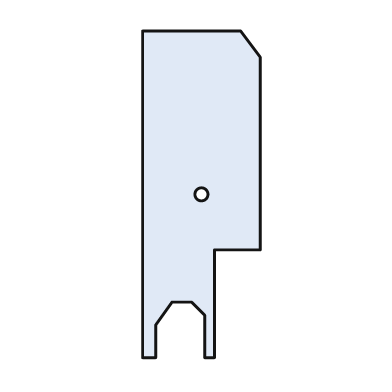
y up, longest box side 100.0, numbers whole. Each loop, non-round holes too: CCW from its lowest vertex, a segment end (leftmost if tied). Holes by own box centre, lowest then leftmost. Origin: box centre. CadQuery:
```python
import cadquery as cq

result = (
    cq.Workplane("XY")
    .moveTo(-18.0, -50.0)
    .lineTo(-14.0, -50.0)
    .lineTo(-14.0, -40.0)
    .lineTo(-9.0, -33.0)
    .lineTo(-3.0, -33.0)
    .lineTo(1.0, -37.0)
    .lineTo(1.0, -50.0)
    .lineTo(4.0, -50.0)
    .lineTo(4.0, -17.0)
    .lineTo(18.0, -17.0)
    .lineTo(18.0, 42.0)
    .lineTo(12.0, 50.0)
    .lineTo(-18.0, 50.0)
    .close()
    .moveTo(0.0, 0.0)
    .circle(2.0)
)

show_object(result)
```